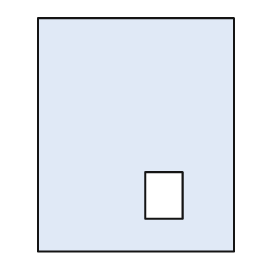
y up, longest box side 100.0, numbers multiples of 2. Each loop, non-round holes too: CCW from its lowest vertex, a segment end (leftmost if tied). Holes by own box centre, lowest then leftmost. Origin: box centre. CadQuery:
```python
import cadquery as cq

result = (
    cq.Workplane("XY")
    .moveTo(-42.0, -50.0)
    .lineTo(42.0, -50.0)
    .lineTo(42.0, 50.0)
    .lineTo(-42.0, 50.0)
    .close()
    .moveTo(4.0, -36.0)
    .lineTo(20.0, -36.0)
    .lineTo(20.0, -16.0)
    .lineTo(4.0, -16.0)
    .close()
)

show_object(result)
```